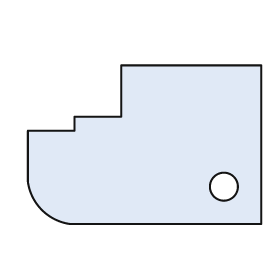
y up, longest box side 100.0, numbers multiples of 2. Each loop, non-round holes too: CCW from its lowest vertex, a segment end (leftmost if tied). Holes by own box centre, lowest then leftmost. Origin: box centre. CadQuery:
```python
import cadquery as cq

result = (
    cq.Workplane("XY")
    .moveTo(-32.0, -34.0)
    .lineTo(50.0, -34.0)
    .lineTo(50.0, 34.0)
    .lineTo(-10.0, 34.0)
    .lineTo(-10.0, 12.0)
    .lineTo(-30.0, 12.0)
    .lineTo(-30.0, 6.0)
    .lineTo(-50.0, 6.0)
    .lineTo(-50.0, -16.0)
    .threePointArc((-44.0, -28.0), (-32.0, -34.0))
    .close()
    .moveTo(34.0, -18.0)
    .circle(6.0)
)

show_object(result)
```